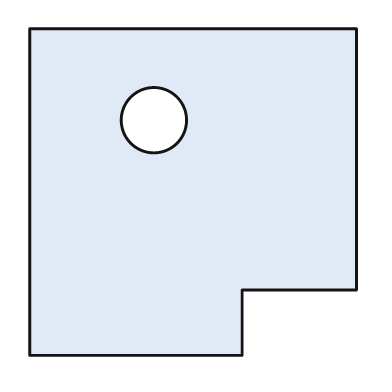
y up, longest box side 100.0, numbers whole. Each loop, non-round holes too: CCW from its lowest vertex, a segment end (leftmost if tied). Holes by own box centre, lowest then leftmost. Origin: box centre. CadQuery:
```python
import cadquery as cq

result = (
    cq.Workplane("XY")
    .moveTo(-50.0, -50.0)
    .lineTo(15.0, -50.0)
    .lineTo(15.0, -30.0)
    .lineTo(50.0, -30.0)
    .lineTo(50.0, 50.0)
    .lineTo(-50.0, 50.0)
    .close()
    .moveTo(-12.0, 22.0)
    .circle(10.0)
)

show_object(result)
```